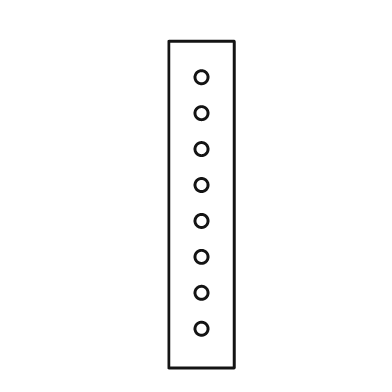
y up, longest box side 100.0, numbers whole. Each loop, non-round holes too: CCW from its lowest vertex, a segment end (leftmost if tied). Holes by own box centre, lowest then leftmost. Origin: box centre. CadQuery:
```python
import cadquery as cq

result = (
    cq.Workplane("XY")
    .moveTo(-10.0, -50.0)
    .lineTo(10.0, -50.0)
    .lineTo(10.0, 50.0)
    .lineTo(-10.0, 50.0)
    .close()
    .moveTo(0.0, -38.0)
    .circle(2.0)
    .moveTo(0.0, -27.0)
    .circle(2.0)
    .moveTo(0.0, -16.0)
    .circle(2.0)
    .moveTo(0.0, -5.0)
    .circle(2.0)
    .moveTo(0.0, 6.0)
    .circle(2.0)
    .moveTo(0.0, 17.0)
    .circle(2.0)
    .moveTo(0.0, 28.0)
    .circle(2.0)
    .moveTo(0.0, 39.0)
    .circle(2.0)
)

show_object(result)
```